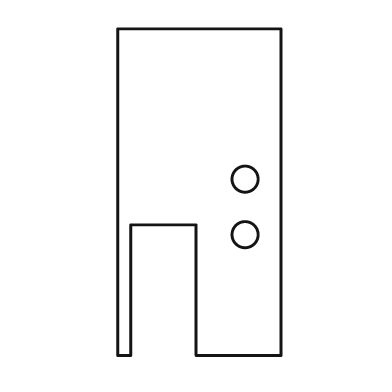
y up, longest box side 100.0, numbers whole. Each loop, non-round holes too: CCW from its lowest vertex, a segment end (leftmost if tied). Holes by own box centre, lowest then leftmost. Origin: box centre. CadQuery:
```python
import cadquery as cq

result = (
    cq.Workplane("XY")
    .moveTo(-25.0, -50.0)
    .lineTo(-21.0, -50.0)
    .lineTo(-21.0, -10.0)
    .lineTo(-1.0, -10.0)
    .lineTo(-1.0, -50.0)
    .lineTo(25.0, -50.0)
    .lineTo(25.0, 50.0)
    .lineTo(-25.0, 50.0)
    .close()
    .moveTo(14.0, -13.0)
    .circle(4.0)
    .moveTo(14.0, 4.0)
    .circle(4.0)
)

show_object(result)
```